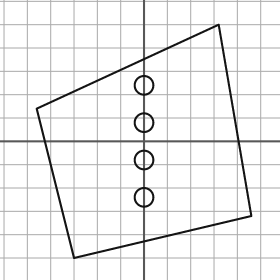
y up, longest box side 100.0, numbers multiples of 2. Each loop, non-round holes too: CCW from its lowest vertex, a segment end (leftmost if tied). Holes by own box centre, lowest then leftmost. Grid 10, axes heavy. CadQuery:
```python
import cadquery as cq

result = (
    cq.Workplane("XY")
    .moveTo(-30.0, -50.0)
    .lineTo(46.0, -32.0)
    .lineTo(32.0, 50.0)
    .lineTo(-46.0, 14.0)
    .close()
    .moveTo(0.0, -24.0)
    .circle(4.0)
    .moveTo(0.0, -8.0)
    .circle(4.0)
    .moveTo(0.0, 8.0)
    .circle(4.0)
    .moveTo(0.0, 24.0)
    .circle(4.0)
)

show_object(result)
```